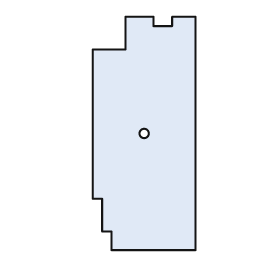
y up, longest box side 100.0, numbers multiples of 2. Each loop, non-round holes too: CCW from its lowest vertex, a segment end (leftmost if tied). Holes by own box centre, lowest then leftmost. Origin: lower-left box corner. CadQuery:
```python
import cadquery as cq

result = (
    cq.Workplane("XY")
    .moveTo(8.0, 0.0)
    .lineTo(44.0, 0.0)
    .lineTo(44.0, 100.0)
    .lineTo(34.0, 100.0)
    .lineTo(34.0, 96.0)
    .lineTo(26.0, 96.0)
    .lineTo(26.0, 100.0)
    .lineTo(14.0, 100.0)
    .lineTo(14.0, 86.0)
    .lineTo(0.0, 86.0)
    .lineTo(0.0, 22.0)
    .lineTo(4.0, 22.0)
    .lineTo(4.0, 8.0)
    .lineTo(8.0, 8.0)
    .close()
    .moveTo(22.0, 50.0)
    .circle(2.0)
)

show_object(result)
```